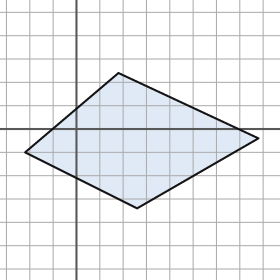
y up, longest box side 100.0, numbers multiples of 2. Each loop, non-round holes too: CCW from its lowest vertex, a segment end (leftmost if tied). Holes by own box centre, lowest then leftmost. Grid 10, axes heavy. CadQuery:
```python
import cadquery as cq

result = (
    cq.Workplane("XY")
    .moveTo(26.0, -34.0)
    .lineTo(78.0, -4.0)
    .lineTo(18.0, 24.0)
    .lineTo(-22.0, -10.0)
    .close()
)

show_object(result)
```